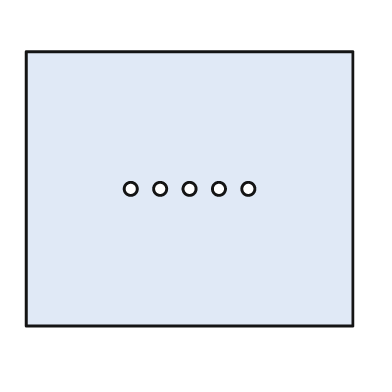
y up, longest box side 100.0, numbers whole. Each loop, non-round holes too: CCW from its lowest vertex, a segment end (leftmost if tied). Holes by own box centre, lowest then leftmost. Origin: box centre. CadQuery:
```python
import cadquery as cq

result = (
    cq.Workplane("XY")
    .moveTo(-50.0, -42.0)
    .lineTo(50.0, -42.0)
    .lineTo(50.0, 42.0)
    .lineTo(-50.0, 42.0)
    .close()
    .moveTo(-18.0, 0.0)
    .circle(2.0)
    .moveTo(-9.0, 0.0)
    .circle(2.0)
    .moveTo(0.0, 0.0)
    .circle(2.0)
    .moveTo(9.0, 0.0)
    .circle(2.0)
    .moveTo(18.0, 0.0)
    .circle(2.0)
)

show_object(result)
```